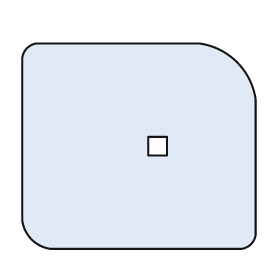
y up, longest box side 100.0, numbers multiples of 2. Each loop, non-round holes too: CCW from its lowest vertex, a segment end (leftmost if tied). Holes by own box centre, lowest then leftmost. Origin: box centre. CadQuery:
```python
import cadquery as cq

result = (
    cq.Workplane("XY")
    .moveTo(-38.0, -44.0)
    .lineTo(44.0, -44.0)
    .threePointArc((48.0, -42.0), (50.0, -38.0))
    .lineTo(50.0, 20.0)
    .threePointArc((42.0, 36.0), (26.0, 44.0))
    .lineTo(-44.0, 44.0)
    .threePointArc((-48.0, 42.0), (-50.0, 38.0))
    .lineTo(-50.0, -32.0)
    .threePointArc((-46.0, -40.0), (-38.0, -44.0))
    .close()
    .moveTo(4.0, -4.0)
    .lineTo(12.0, -4.0)
    .lineTo(12.0, 4.0)
    .lineTo(4.0, 4.0)
    .close()
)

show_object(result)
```